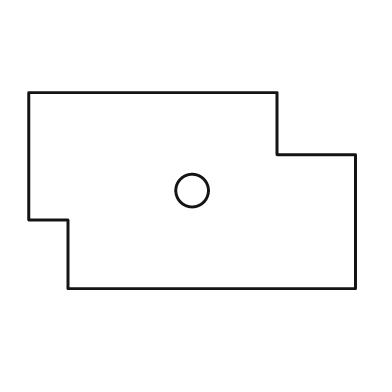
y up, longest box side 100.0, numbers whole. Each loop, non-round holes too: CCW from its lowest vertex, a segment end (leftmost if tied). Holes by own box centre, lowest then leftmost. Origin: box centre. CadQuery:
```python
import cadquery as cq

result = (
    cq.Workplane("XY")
    .moveTo(-38.0, -30.0)
    .lineTo(50.0, -30.0)
    .lineTo(50.0, 11.0)
    .lineTo(26.0, 11.0)
    .lineTo(26.0, 30.0)
    .lineTo(-50.0, 30.0)
    .lineTo(-50.0, -9.0)
    .lineTo(-38.0, -9.0)
    .close()
    .moveTo(0.0, 0.0)
    .circle(5.0)
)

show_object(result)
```